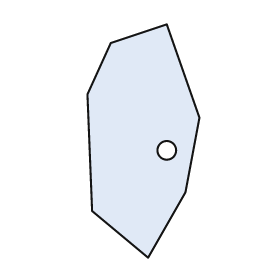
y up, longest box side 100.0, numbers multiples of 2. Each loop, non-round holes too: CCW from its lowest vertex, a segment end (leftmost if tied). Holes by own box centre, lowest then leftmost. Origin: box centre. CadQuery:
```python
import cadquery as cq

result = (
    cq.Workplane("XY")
    .moveTo(2.0, -50.0)
    .lineTo(18.0, -22.0)
    .lineTo(24.0, 10.0)
    .lineTo(10.0, 50.0)
    .lineTo(-14.0, 42.0)
    .lineTo(-24.0, 20.0)
    .lineTo(-22.0, -30.0)
    .close()
    .moveTo(10.0, -4.0)
    .circle(4.0)
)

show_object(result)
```